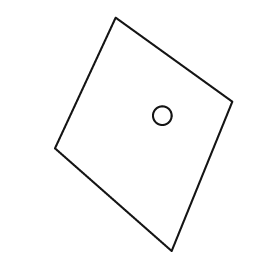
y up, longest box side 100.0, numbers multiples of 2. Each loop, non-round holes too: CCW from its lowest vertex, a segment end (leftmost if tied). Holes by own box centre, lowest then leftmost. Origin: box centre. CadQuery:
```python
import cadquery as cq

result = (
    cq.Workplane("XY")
    .moveTo(12.0, -50.0)
    .lineTo(38.0, 14.0)
    .lineTo(-12.0, 50.0)
    .lineTo(-38.0, -6.0)
    .close()
    .moveTo(8.0, 8.0)
    .circle(4.0)
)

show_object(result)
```